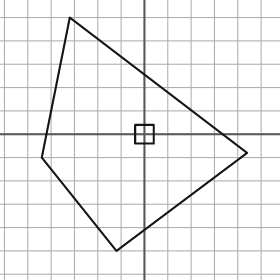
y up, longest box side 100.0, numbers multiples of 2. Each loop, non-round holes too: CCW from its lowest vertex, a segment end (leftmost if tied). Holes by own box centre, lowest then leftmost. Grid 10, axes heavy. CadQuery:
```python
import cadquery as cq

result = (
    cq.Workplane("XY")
    .moveTo(-12.0, -50.0)
    .lineTo(44.0, -8.0)
    .lineTo(-32.0, 50.0)
    .lineTo(-44.0, -10.0)
    .close()
    .moveTo(-4.0, -4.0)
    .lineTo(4.0, -4.0)
    .lineTo(4.0, 4.0)
    .lineTo(-4.0, 4.0)
    .close()
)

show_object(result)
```